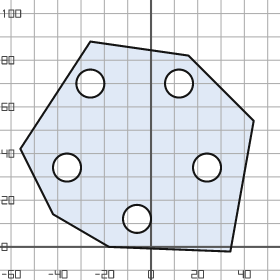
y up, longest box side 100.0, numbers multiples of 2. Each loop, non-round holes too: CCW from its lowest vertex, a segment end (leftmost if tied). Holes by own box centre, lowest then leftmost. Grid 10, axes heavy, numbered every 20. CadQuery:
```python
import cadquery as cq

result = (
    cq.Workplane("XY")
    .moveTo(34.0, -2.0)
    .lineTo(44.0, 54.0)
    .lineTo(16.0, 82.0)
    .lineTo(-26.0, 88.0)
    .lineTo(-56.0, 42.0)
    .lineTo(-42.0, 14.0)
    .lineTo(-18.0, 0.0)
    .close()
    .moveTo(-6.0, 12.0)
    .circle(6.0)
    .moveTo(-36.0, 34.0)
    .circle(6.0)
    .moveTo(24.0, 34.0)
    .circle(6.0)
    .moveTo(-26.0, 70.0)
    .circle(6.0)
    .moveTo(12.0, 70.0)
    .circle(6.0)
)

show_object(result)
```